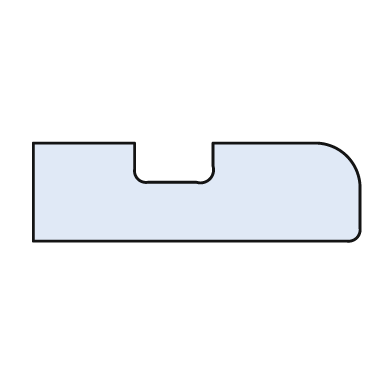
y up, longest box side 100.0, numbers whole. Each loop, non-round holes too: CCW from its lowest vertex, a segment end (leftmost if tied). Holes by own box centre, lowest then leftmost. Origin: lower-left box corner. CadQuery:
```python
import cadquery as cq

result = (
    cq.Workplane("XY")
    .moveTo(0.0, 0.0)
    .lineTo(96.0, 0.0)
    .threePointArc((99.0, 1.0), (100.0, 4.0))
    .lineTo(100.0, 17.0)
    .threePointArc((96.0, 26.0), (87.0, 30.0))
    .lineTo(55.0, 30.0)
    .lineTo(55.0, 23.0)
    .threePointArc((54.0, 19.0), (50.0, 18.0))
    .lineTo(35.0, 18.0)
    .threePointArc((32.0, 19.0), (31.0, 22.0))
    .lineTo(31.0, 30.0)
    .lineTo(0.0, 30.0)
    .close()
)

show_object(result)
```